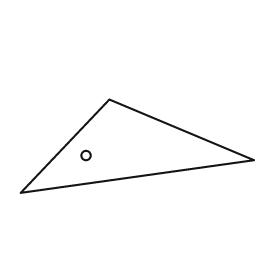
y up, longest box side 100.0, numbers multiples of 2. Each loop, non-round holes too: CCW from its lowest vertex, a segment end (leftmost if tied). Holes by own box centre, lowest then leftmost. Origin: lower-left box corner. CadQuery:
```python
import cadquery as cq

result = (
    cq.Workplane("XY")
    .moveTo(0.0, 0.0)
    .lineTo(100.0, 14.0)
    .lineTo(38.0, 40.0)
    .close()
    .moveTo(28.0, 16.0)
    .circle(2.0)
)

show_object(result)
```